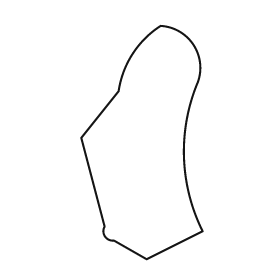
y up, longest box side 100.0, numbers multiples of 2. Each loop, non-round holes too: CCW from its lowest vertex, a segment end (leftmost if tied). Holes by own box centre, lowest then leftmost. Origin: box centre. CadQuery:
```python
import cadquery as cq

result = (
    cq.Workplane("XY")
    .moveTo(2.0, -50.0)
    .lineTo(26.0, -38.0)
    .threePointArc((18.0, -6.0), (24.0, 26.0))
    .threePointArc((22.0, 42.0), (8.0, 50.0))
    .threePointArc((-4.0, 38.0), (-10.0, 22.0))
    .lineTo(-26.0, 2.0)
    .lineTo(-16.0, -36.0)
    .threePointArc((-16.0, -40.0), (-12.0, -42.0))
    .close()
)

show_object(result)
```